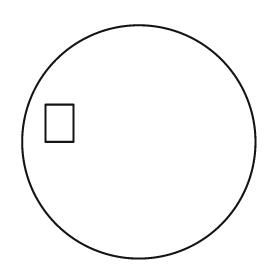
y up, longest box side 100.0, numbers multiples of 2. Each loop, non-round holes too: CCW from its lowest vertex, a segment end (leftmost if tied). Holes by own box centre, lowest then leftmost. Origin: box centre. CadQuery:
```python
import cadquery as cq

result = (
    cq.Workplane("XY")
    .moveTo(0.0, 0.0)
    .circle(50.0)
    .moveTo(-40.0, 0.0)
    .lineTo(-28.0, 0.0)
    .lineTo(-28.0, 16.0)
    .lineTo(-40.0, 16.0)
    .close()
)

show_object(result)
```